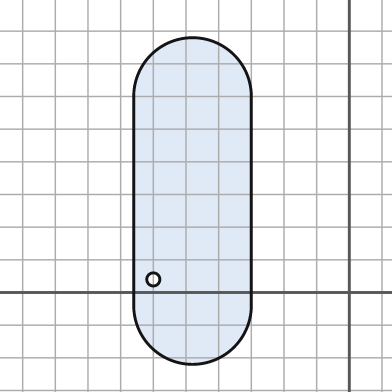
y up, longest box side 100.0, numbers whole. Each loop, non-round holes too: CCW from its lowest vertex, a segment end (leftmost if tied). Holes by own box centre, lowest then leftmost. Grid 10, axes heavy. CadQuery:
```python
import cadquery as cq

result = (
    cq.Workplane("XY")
    .moveTo(-66.0, -4.0)
    .threePointArc((-48.0, -22.0), (-30.0, -4.0))
    .lineTo(-30.0, 60.0)
    .threePointArc((-48.0, 78.0), (-66.0, 60.0))
    .close()
    .moveTo(-60.0, 4.0)
    .circle(2.0)
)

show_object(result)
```